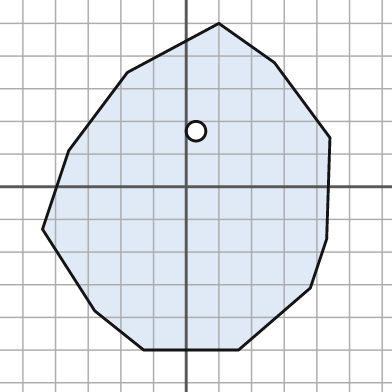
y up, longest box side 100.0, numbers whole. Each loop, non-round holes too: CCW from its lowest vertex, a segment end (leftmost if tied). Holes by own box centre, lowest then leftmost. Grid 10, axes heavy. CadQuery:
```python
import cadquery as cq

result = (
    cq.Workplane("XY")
    .moveTo(-13.0, -50.0)
    .lineTo(16.0, -50.0)
    .lineTo(38.0, -31.0)
    .lineTo(43.0, -16.0)
    .lineTo(44.0, 15.0)
    .lineTo(27.0, 38.0)
    .lineTo(10.0, 50.0)
    .lineTo(-18.0, 35.0)
    .lineTo(-36.0, 11.0)
    .lineTo(-44.0, -13.0)
    .lineTo(-28.0, -38.0)
    .close()
    .moveTo(3.0, 17.0)
    .circle(3.0)
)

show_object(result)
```